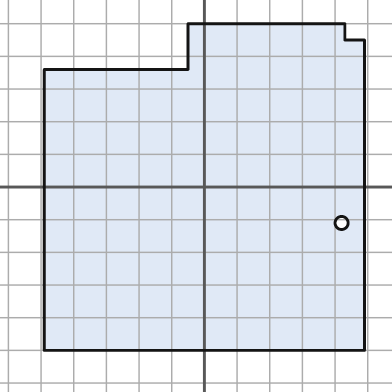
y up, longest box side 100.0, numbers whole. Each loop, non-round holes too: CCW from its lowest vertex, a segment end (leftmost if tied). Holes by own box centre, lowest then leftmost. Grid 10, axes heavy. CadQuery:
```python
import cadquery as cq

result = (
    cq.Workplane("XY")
    .moveTo(-49.0, -50.0)
    .lineTo(49.0, -50.0)
    .lineTo(49.0, 45.0)
    .lineTo(43.0, 45.0)
    .lineTo(43.0, 50.0)
    .lineTo(-5.0, 50.0)
    .lineTo(-5.0, 36.0)
    .lineTo(-49.0, 36.0)
    .close()
    .moveTo(42.0, -11.0)
    .circle(2.0)
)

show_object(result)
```